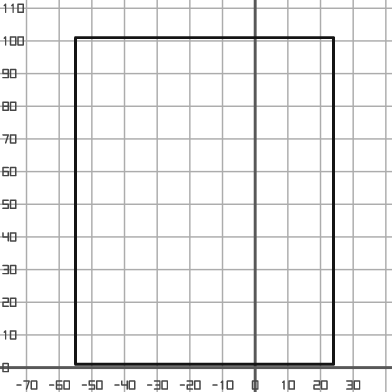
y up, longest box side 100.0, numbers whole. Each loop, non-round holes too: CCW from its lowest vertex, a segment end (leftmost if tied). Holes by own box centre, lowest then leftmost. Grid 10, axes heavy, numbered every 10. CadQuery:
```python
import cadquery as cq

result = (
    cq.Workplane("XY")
    .moveTo(-55.0, 1.0)
    .lineTo(24.0, 1.0)
    .lineTo(24.0, 101.0)
    .lineTo(-55.0, 101.0)
    .close()
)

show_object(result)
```